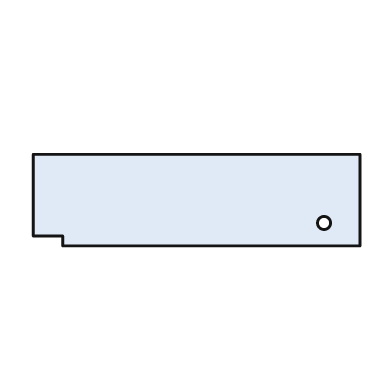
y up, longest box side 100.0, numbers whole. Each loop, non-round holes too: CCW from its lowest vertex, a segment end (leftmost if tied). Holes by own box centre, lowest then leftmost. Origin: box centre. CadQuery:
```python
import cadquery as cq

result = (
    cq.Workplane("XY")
    .moveTo(-41.0, -14.0)
    .lineTo(50.0, -14.0)
    .lineTo(50.0, 14.0)
    .lineTo(-50.0, 14.0)
    .lineTo(-50.0, -11.0)
    .lineTo(-41.0, -11.0)
    .close()
    .moveTo(39.0, -7.0)
    .circle(2.0)
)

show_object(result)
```